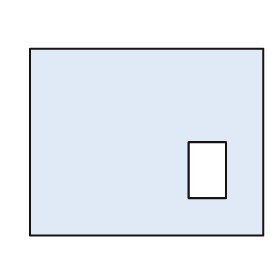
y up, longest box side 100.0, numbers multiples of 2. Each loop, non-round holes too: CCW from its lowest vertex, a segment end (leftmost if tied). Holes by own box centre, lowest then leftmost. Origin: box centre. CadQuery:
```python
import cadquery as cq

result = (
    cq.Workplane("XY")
    .moveTo(-50.0, -40.0)
    .lineTo(50.0, -40.0)
    .lineTo(50.0, 40.0)
    .lineTo(-50.0, 40.0)
    .close()
    .moveTo(18.0, -24.0)
    .lineTo(34.0, -24.0)
    .lineTo(34.0, 0.0)
    .lineTo(18.0, 0.0)
    .close()
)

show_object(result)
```